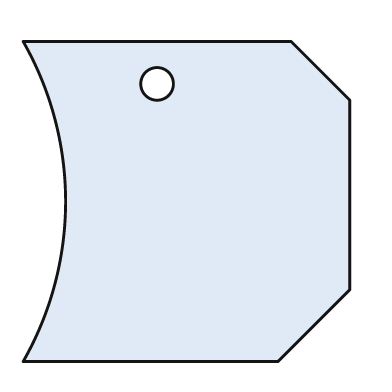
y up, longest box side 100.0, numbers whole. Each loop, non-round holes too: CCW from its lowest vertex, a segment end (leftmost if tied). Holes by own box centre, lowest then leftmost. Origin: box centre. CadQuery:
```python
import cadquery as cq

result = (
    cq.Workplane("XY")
    .moveTo(-50.0, -49.0)
    .lineTo(28.0, -49.0)
    .lineTo(50.0, -27.0)
    .lineTo(50.0, 31.0)
    .lineTo(32.0, 49.0)
    .lineTo(-50.0, 49.0)
    .threePointArc((-37.0, 0.0), (-50.0, -49.0))
    .close()
    .moveTo(-9.0, 36.0)
    .circle(5.0)
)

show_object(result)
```